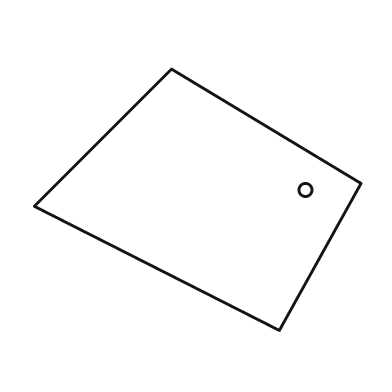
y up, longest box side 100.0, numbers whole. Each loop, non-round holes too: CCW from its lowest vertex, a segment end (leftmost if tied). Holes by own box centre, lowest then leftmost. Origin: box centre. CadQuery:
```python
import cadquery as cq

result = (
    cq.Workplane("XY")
    .moveTo(25.0, -40.0)
    .lineTo(50.0, 5.0)
    .lineTo(-8.0, 40.0)
    .lineTo(-50.0, -2.0)
    .close()
    .moveTo(33.0, 3.0)
    .circle(2.0)
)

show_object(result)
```